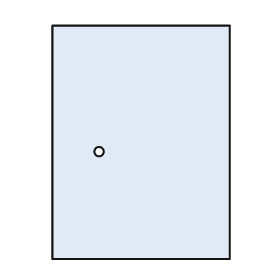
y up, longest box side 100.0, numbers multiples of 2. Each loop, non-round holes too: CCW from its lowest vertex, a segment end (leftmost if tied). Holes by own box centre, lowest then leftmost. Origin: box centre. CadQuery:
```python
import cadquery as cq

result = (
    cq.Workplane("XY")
    .moveTo(-38.0, -50.0)
    .lineTo(38.0, -50.0)
    .lineTo(38.0, 50.0)
    .lineTo(-38.0, 50.0)
    .close()
    .moveTo(-18.0, -4.0)
    .circle(2.0)
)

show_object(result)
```